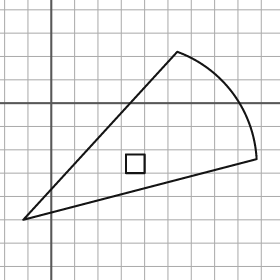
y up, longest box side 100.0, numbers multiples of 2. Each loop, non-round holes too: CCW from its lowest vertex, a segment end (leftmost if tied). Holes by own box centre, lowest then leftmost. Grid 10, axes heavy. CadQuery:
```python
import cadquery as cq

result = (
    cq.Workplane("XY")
    .moveTo(-12.0, -50.0)
    .lineTo(88.0, -24.0)
    .threePointArc((78.0, 4.0), (54.0, 22.0))
    .close()
    .moveTo(32.0, -30.0)
    .lineTo(40.0, -30.0)
    .lineTo(40.0, -22.0)
    .lineTo(32.0, -22.0)
    .close()
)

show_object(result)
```